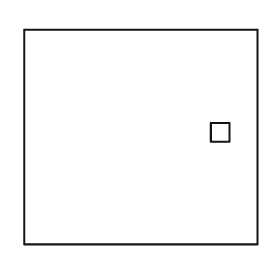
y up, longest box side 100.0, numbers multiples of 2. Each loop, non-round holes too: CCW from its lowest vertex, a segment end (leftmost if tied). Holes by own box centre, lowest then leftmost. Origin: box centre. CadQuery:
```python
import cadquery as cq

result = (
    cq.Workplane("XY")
    .moveTo(-50.0, -46.0)
    .lineTo(50.0, -46.0)
    .lineTo(50.0, 46.0)
    .lineTo(-50.0, 46.0)
    .close()
    .moveTo(30.0, -2.0)
    .lineTo(38.0, -2.0)
    .lineTo(38.0, 6.0)
    .lineTo(30.0, 6.0)
    .close()
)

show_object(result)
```